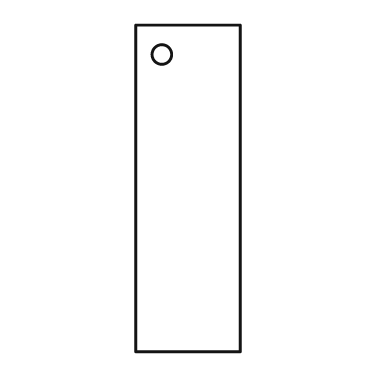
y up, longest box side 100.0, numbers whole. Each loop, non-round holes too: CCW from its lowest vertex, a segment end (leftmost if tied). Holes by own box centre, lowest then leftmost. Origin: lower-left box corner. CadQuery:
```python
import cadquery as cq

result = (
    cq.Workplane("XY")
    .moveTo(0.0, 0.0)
    .lineTo(32.0, 0.0)
    .lineTo(32.0, 100.0)
    .lineTo(0.0, 100.0)
    .close()
    .moveTo(8.0, 91.0)
    .circle(3.0)
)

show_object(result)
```